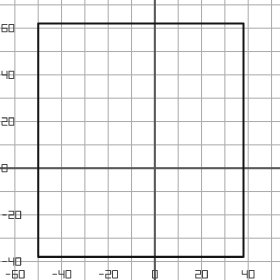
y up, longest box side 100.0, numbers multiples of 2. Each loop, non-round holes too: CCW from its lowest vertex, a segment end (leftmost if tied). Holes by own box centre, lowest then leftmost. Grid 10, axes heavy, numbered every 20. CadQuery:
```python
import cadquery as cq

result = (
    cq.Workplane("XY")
    .moveTo(-50.0, -38.0)
    .lineTo(38.0, -38.0)
    .lineTo(38.0, 62.0)
    .lineTo(-50.0, 62.0)
    .close()
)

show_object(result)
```